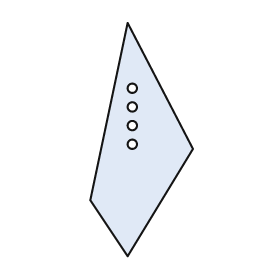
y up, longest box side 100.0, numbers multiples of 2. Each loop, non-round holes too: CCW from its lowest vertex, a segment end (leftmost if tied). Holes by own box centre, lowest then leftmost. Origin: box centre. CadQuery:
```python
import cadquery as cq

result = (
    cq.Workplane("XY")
    .moveTo(-6.0, -50.0)
    .lineTo(22.0, -4.0)
    .lineTo(-6.0, 50.0)
    .lineTo(-22.0, -26.0)
    .close()
    .moveTo(-4.0, -2.0)
    .circle(2.0)
    .moveTo(-4.0, 6.0)
    .circle(2.0)
    .moveTo(-4.0, 14.0)
    .circle(2.0)
    .moveTo(-4.0, 22.0)
    .circle(2.0)
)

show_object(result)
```